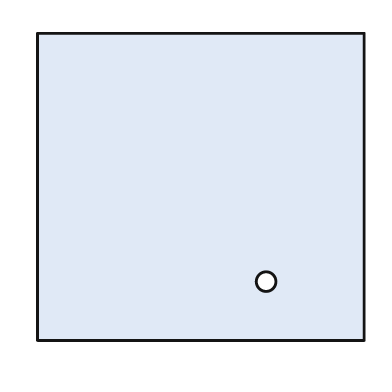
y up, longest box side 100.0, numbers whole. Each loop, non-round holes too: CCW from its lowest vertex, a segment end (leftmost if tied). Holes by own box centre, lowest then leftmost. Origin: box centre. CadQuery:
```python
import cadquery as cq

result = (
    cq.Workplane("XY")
    .moveTo(-50.0, -47.0)
    .lineTo(50.0, -47.0)
    .lineTo(50.0, 47.0)
    .lineTo(-50.0, 47.0)
    .close()
    .moveTo(20.0, -29.0)
    .circle(3.0)
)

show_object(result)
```